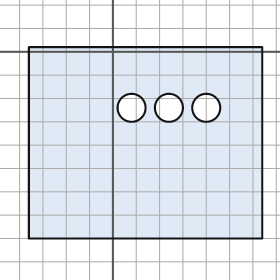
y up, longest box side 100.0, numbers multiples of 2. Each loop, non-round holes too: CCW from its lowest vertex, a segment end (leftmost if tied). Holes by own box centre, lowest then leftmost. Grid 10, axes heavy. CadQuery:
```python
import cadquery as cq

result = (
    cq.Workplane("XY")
    .moveTo(-36.0, -80.0)
    .lineTo(64.0, -80.0)
    .lineTo(64.0, 2.0)
    .lineTo(-36.0, 2.0)
    .close()
    .moveTo(8.0, -24.0)
    .circle(6.0)
    .moveTo(24.0, -24.0)
    .circle(6.0)
    .moveTo(40.0, -24.0)
    .circle(6.0)
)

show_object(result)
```